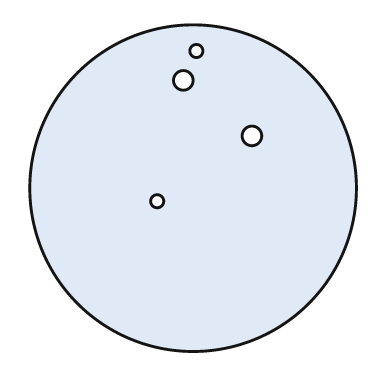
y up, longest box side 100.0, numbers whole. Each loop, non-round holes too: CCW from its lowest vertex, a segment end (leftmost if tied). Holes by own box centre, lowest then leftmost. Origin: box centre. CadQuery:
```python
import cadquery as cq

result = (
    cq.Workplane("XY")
    .moveTo(0.0, 0.0)
    .circle(50.0)
    .moveTo(-11.0, -4.0)
    .circle(2.0)
    .moveTo(18.0, 16.0)
    .circle(3.0)
    .moveTo(-3.0, 33.0)
    .circle(3.0)
    .moveTo(1.0, 42.0)
    .circle(2.0)
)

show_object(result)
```